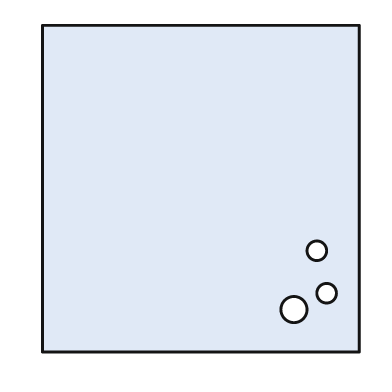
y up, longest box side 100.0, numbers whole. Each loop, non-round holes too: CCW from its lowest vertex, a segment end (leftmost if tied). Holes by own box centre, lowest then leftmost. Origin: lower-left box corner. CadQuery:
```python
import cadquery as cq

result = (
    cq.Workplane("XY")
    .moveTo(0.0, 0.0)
    .lineTo(97.0, 0.0)
    .lineTo(97.0, 100.0)
    .lineTo(0.0, 100.0)
    .close()
    .moveTo(77.0, 13.0)
    .circle(4.0)
    .moveTo(87.0, 18.0)
    .circle(3.0)
    .moveTo(84.0, 31.0)
    .circle(3.0)
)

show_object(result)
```